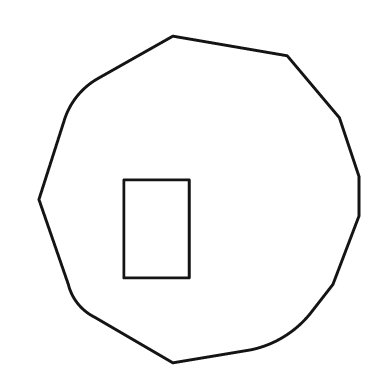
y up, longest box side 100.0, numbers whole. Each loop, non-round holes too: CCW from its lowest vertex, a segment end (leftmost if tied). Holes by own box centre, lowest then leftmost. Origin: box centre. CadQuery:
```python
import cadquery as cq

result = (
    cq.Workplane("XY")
    .moveTo(-8.0, -50.0)
    .lineTo(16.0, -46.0)
    .threePointArc((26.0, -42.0), (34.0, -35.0))
    .lineTo(41.0, -26.0)
    .lineTo(49.0, -5.0)
    .lineTo(49.0, 7.0)
    .lineTo(43.0, 25.0)
    .lineTo(27.0, 44.0)
    .lineTo(-8.0, 50.0)
    .lineTo(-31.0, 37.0)
    .threePointArc((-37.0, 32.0), (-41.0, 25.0))
    .lineTo(-49.0, 0.0)
    .lineTo(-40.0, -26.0)
    .threePointArc((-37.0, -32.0), (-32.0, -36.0))
    .close()
    .moveTo(-23.0, -24.0)
    .lineTo(-3.0, -24.0)
    .lineTo(-3.0, 6.0)
    .lineTo(-23.0, 6.0)
    .close()
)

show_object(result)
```